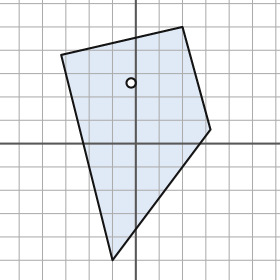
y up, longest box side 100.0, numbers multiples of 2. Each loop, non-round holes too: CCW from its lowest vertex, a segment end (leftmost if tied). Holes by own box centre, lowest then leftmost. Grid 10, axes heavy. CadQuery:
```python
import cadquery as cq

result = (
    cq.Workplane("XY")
    .moveTo(-10.0, -50.0)
    .lineTo(32.0, 6.0)
    .lineTo(20.0, 50.0)
    .lineTo(-32.0, 38.0)
    .close()
    .moveTo(-2.0, 26.0)
    .circle(2.0)
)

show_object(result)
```